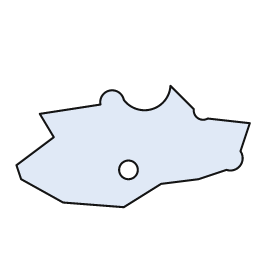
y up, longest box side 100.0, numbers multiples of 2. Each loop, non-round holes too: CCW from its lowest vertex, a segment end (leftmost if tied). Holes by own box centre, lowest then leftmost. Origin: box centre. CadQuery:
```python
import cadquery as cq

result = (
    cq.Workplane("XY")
    .moveTo(-4.0, -26.0)
    .lineTo(12.0, -16.0)
    .lineTo(28.0, -14.0)
    .lineTo(40.0, -10.0)
    .threePointArc((46.0, -8.0), (46.0, -2.0))
    .lineTo(50.0, 10.0)
    .lineTo(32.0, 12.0)
    .threePointArc((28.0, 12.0), (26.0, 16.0))
    .lineTo(16.0, 26.0)
    .threePointArc((8.0, 16.0), (-4.0, 20.0))
    .threePointArc((-10.0, 24.0), (-14.0, 18.0))
    .lineTo(-40.0, 14.0)
    .lineTo(-34.0, 4.0)
    .lineTo(-50.0, -8.0)
    .lineTo(-48.0, -14.0)
    .lineTo(-30.0, -24.0)
    .close()
    .moveTo(-2.0, -10.0)
    .circle(4.0)
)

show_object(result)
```